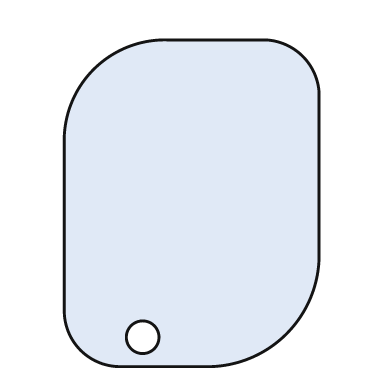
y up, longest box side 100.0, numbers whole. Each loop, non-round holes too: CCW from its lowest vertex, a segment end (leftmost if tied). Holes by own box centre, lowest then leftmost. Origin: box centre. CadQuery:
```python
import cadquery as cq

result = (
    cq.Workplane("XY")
    .moveTo(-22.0, -50.0)
    .lineTo(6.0, -50.0)
    .threePointArc((29.0, -40.0), (39.0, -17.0))
    .lineTo(39.0, 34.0)
    .threePointArc((34.0, 45.0), (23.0, 50.0))
    .lineTo(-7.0, 50.0)
    .threePointArc((-30.0, 41.0), (-39.0, 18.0))
    .lineTo(-39.0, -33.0)
    .threePointArc((-34.0, -45.0), (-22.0, -50.0))
    .close()
    .moveTo(-15.0, -41.0)
    .circle(5.0)
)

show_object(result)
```